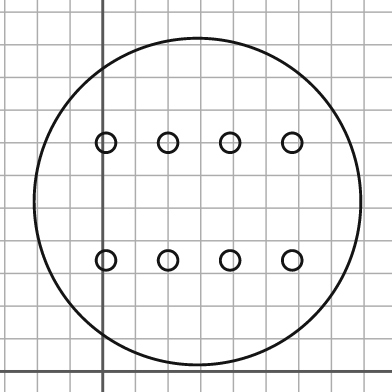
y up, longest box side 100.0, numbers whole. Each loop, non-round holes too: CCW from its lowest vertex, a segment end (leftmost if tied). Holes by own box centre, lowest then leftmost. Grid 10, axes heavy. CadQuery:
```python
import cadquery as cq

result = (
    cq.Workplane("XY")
    .moveTo(29.0, 52.0)
    .circle(50.0)
    .moveTo(1.0, 34.0)
    .circle(3.0)
    .moveTo(20.0, 34.0)
    .circle(3.0)
    .moveTo(39.0, 34.0)
    .circle(3.0)
    .moveTo(58.0, 34.0)
    .circle(3.0)
    .moveTo(1.0, 70.0)
    .circle(3.0)
    .moveTo(20.0, 70.0)
    .circle(3.0)
    .moveTo(39.0, 70.0)
    .circle(3.0)
    .moveTo(58.0, 70.0)
    .circle(3.0)
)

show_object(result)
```